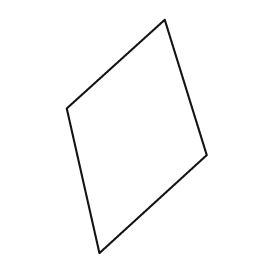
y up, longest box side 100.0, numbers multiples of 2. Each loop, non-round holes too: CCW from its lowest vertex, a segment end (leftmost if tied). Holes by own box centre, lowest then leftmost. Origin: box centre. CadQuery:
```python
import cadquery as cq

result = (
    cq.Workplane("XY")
    .moveTo(-16.0, -50.0)
    .lineTo(30.0, -8.0)
    .lineTo(12.0, 50.0)
    .lineTo(-30.0, 12.0)
    .close()
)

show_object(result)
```